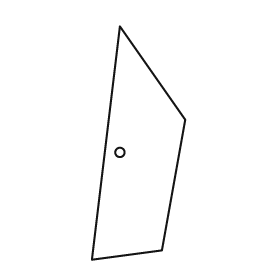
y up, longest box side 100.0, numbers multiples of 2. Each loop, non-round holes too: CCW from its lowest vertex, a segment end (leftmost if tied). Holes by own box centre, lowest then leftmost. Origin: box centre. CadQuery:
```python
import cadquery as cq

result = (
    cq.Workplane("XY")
    .moveTo(-20.0, -50.0)
    .lineTo(10.0, -46.0)
    .lineTo(20.0, 10.0)
    .lineTo(-8.0, 50.0)
    .close()
    .moveTo(-8.0, -4.0)
    .circle(2.0)
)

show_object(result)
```